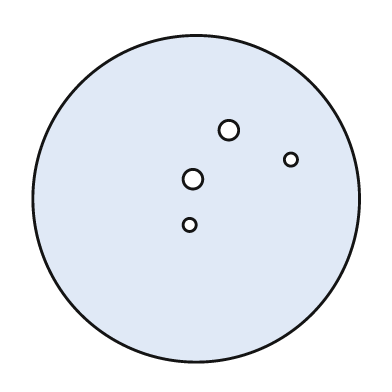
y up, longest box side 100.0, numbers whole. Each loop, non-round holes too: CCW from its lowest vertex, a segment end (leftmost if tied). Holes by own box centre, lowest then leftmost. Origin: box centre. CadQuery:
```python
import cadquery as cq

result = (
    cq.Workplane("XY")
    .moveTo(0.0, 0.0)
    .circle(50.0)
    .moveTo(-2.0, -8.0)
    .circle(2.0)
    .moveTo(-1.0, 6.0)
    .circle(3.0)
    .moveTo(29.0, 12.0)
    .circle(2.0)
    .moveTo(10.0, 21.0)
    .circle(3.0)
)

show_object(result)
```